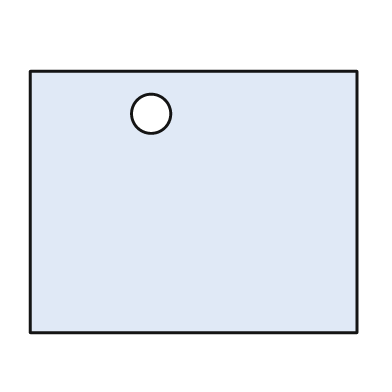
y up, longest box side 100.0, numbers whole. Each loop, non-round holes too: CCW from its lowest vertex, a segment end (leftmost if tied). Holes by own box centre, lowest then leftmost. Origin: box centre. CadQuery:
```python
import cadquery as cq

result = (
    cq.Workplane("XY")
    .moveTo(-50.0, -40.0)
    .lineTo(50.0, -40.0)
    .lineTo(50.0, 40.0)
    .lineTo(-50.0, 40.0)
    .close()
    .moveTo(-13.0, 27.0)
    .circle(6.0)
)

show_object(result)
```